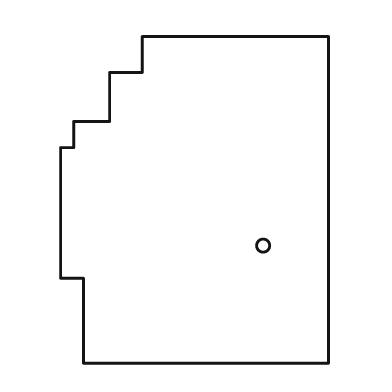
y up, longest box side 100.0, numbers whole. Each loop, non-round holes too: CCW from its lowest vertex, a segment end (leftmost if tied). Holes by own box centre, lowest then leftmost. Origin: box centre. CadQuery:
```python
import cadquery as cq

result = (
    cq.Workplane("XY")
    .moveTo(-34.0, -50.0)
    .lineTo(41.0, -50.0)
    .lineTo(41.0, 50.0)
    .lineTo(-16.0, 50.0)
    .lineTo(-16.0, 39.0)
    .lineTo(-26.0, 39.0)
    .lineTo(-26.0, 24.0)
    .lineTo(-37.0, 24.0)
    .lineTo(-37.0, 16.0)
    .lineTo(-41.0, 16.0)
    .lineTo(-41.0, -24.0)
    .lineTo(-34.0, -24.0)
    .close()
    .moveTo(21.0, -14.0)
    .circle(2.0)
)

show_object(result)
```